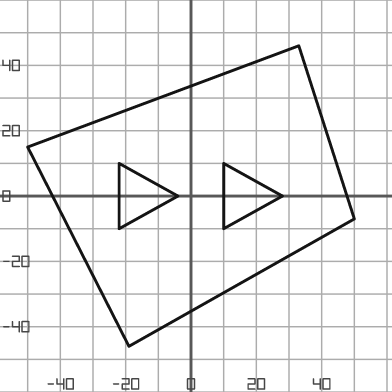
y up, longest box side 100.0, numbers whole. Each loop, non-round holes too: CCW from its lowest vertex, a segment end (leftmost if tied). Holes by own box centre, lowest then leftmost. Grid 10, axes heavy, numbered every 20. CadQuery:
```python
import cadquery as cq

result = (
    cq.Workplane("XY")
    .moveTo(-19.0, -46.0)
    .lineTo(50.0, -7.0)
    .lineTo(33.0, 46.0)
    .lineTo(-50.0, 15.0)
    .close()
    .moveTo(-22.0, -10.0)
    .lineTo(-4.0, 0.0)
    .lineTo(-22.0, 10.0)
    .close()
    .moveTo(10.0, -10.0)
    .lineTo(28.0, 0.0)
    .lineTo(10.0, 10.0)
    .close()
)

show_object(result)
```